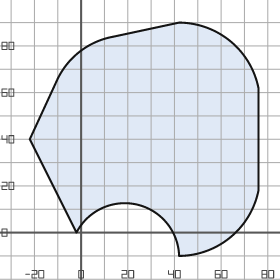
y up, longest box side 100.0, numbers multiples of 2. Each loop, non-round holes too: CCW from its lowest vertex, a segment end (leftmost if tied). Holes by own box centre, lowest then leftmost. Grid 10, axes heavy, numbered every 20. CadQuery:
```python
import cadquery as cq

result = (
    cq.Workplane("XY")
    .moveTo(42.0, -10.0)
    .threePointArc((64.0, -2.0), (76.0, 18.0))
    .lineTo(76.0, 62.0)
    .threePointArc((64.0, 82.0), (42.0, 90.0))
    .lineTo(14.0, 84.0)
    .threePointArc((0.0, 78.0), (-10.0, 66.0))
    .lineTo(-22.0, 40.0)
    .lineTo(-2.0, 0.0)
    .threePointArc((24.0, 12.0), (42.0, -10.0))
    .close()
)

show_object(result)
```